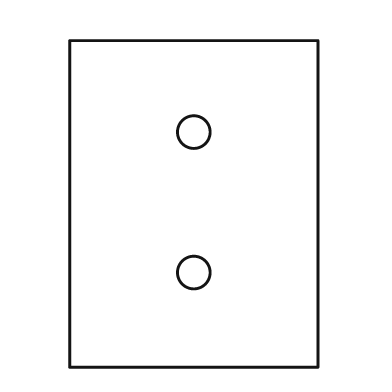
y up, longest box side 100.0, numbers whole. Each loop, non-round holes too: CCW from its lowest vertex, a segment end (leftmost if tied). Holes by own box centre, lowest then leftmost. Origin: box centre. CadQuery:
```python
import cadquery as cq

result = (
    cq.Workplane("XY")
    .moveTo(-38.0, -50.0)
    .lineTo(38.0, -50.0)
    .lineTo(38.0, 50.0)
    .lineTo(-38.0, 50.0)
    .close()
    .moveTo(0.0, -21.0)
    .circle(5.0)
    .moveTo(0.0, 22.0)
    .circle(5.0)
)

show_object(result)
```